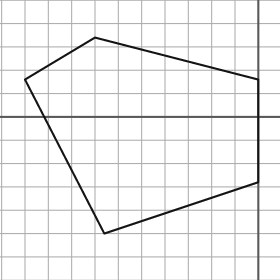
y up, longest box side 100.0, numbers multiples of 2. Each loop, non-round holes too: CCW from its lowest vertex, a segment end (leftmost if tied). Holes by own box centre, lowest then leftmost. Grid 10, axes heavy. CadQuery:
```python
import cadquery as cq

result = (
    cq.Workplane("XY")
    .moveTo(-66.0, -50.0)
    .lineTo(0.0, -28.0)
    .lineTo(0.0, 16.0)
    .lineTo(-70.0, 34.0)
    .lineTo(-100.0, 16.0)
    .close()
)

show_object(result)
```